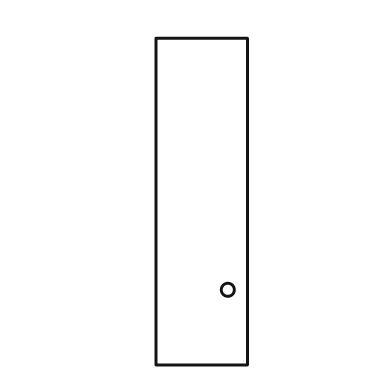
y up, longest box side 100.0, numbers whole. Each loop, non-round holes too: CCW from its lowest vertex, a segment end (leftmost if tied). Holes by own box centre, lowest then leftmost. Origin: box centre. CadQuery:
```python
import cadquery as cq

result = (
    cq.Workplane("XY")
    .moveTo(-14.0, -50.0)
    .lineTo(14.0, -50.0)
    .lineTo(14.0, 50.0)
    .lineTo(-14.0, 50.0)
    .close()
    .moveTo(8.0, -27.0)
    .circle(2.0)
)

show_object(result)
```